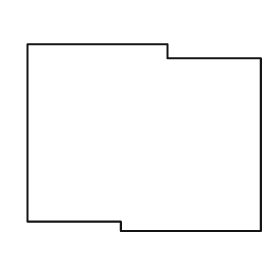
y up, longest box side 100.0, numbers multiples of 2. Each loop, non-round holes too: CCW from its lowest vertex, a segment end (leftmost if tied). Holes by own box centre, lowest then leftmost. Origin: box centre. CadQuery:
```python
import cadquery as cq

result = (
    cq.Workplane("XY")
    .moveTo(-10.0, -40.0)
    .lineTo(50.0, -40.0)
    .lineTo(50.0, 34.0)
    .lineTo(10.0, 34.0)
    .lineTo(10.0, 40.0)
    .lineTo(-50.0, 40.0)
    .lineTo(-50.0, -36.0)
    .lineTo(-10.0, -36.0)
    .close()
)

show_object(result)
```